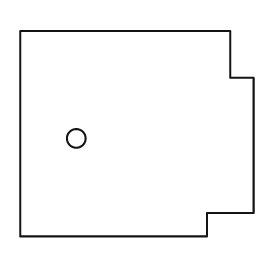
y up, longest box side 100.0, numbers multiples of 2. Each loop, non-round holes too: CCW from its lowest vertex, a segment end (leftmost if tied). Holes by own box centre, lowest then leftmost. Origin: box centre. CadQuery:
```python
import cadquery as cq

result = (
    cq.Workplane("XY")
    .moveTo(-50.0, -44.0)
    .lineTo(30.0, -44.0)
    .lineTo(30.0, -34.0)
    .lineTo(50.0, -34.0)
    .lineTo(50.0, 24.0)
    .lineTo(40.0, 24.0)
    .lineTo(40.0, 44.0)
    .lineTo(-50.0, 44.0)
    .close()
    .moveTo(-26.0, -2.0)
    .circle(4.0)
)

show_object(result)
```